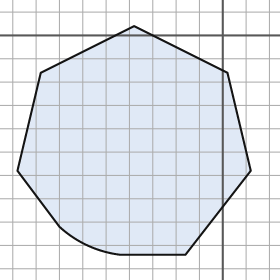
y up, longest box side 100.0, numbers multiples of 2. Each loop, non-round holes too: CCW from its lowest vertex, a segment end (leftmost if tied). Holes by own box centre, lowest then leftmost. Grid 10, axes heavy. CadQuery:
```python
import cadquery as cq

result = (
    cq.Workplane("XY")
    .moveTo(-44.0, -94.0)
    .lineTo(-16.0, -94.0)
    .lineTo(12.0, -58.0)
    .lineTo(2.0, -16.0)
    .lineTo(-38.0, 4.0)
    .lineTo(-78.0, -16.0)
    .lineTo(-88.0, -58.0)
    .lineTo(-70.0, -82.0)
    .threePointArc((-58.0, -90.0), (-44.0, -94.0))
    .close()
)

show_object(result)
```